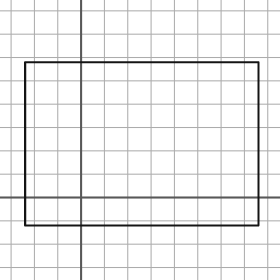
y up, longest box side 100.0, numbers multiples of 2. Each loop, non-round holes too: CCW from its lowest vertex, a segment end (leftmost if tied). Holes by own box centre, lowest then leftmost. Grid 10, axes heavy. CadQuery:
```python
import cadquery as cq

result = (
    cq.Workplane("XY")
    .moveTo(-24.0, -12.0)
    .lineTo(76.0, -12.0)
    .lineTo(76.0, 58.0)
    .lineTo(-24.0, 58.0)
    .close()
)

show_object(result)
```